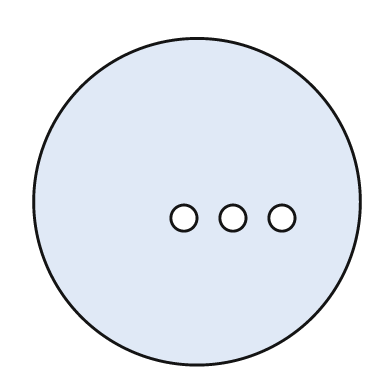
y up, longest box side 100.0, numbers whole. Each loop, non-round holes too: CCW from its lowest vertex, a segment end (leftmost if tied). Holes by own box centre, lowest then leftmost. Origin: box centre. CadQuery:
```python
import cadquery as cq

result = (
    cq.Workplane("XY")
    .moveTo(0.0, 0.0)
    .circle(50.0)
    .moveTo(-4.0, -5.0)
    .circle(4.0)
    .moveTo(11.0, -5.0)
    .circle(4.0)
    .moveTo(26.0, -5.0)
    .circle(4.0)
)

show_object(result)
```